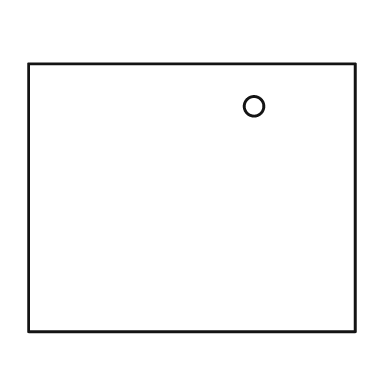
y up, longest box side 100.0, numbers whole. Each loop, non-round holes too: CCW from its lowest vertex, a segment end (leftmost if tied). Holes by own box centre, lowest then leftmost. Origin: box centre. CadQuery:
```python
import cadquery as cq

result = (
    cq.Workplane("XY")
    .moveTo(-50.0, -41.0)
    .lineTo(50.0, -41.0)
    .lineTo(50.0, 41.0)
    .lineTo(-50.0, 41.0)
    .close()
    .moveTo(19.0, 28.0)
    .circle(3.0)
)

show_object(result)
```